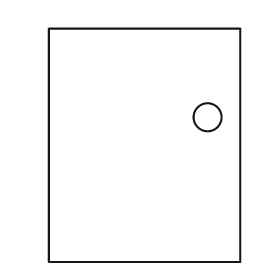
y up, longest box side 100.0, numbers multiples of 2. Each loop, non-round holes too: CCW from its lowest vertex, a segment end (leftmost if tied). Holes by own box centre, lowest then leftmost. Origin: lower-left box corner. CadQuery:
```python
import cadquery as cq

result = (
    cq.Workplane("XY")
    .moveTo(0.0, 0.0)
    .lineTo(82.0, 0.0)
    .lineTo(82.0, 100.0)
    .lineTo(0.0, 100.0)
    .close()
    .moveTo(68.0, 62.0)
    .circle(6.0)
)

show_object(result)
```